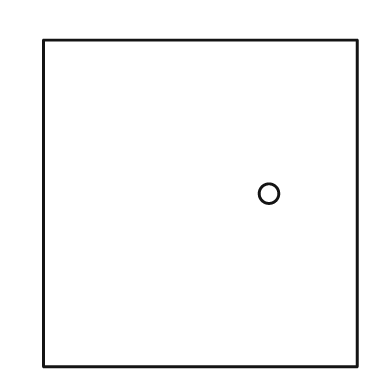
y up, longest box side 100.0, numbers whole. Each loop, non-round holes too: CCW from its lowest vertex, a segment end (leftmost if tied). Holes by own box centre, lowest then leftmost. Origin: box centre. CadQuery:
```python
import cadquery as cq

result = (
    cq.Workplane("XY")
    .moveTo(-48.0, -50.0)
    .lineTo(48.0, -50.0)
    .lineTo(48.0, 50.0)
    .lineTo(-48.0, 50.0)
    .close()
    .moveTo(21.0, 3.0)
    .circle(3.0)
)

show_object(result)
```